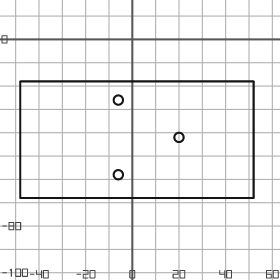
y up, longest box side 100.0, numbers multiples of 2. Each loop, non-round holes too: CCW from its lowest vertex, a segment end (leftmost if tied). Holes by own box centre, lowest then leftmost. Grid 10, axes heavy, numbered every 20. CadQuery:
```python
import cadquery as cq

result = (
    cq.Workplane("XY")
    .moveTo(-48.0, -68.0)
    .lineTo(52.0, -68.0)
    .lineTo(52.0, -18.0)
    .lineTo(-48.0, -18.0)
    .close()
    .moveTo(-6.0, -58.0)
    .circle(2.0)
    .moveTo(20.0, -42.0)
    .circle(2.0)
    .moveTo(-6.0, -26.0)
    .circle(2.0)
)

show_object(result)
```